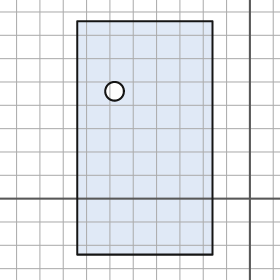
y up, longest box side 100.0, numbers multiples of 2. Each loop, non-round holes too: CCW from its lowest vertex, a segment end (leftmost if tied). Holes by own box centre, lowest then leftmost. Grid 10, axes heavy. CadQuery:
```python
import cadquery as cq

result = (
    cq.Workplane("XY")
    .moveTo(-74.0, -24.0)
    .lineTo(-16.0, -24.0)
    .lineTo(-16.0, 76.0)
    .lineTo(-74.0, 76.0)
    .close()
    .moveTo(-58.0, 46.0)
    .circle(4.0)
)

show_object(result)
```